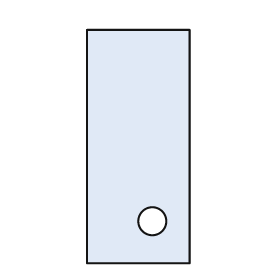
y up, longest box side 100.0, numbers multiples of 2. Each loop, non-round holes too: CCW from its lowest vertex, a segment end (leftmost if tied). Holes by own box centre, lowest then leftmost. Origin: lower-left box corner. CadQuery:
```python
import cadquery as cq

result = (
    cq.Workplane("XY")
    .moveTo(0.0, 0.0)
    .lineTo(44.0, 0.0)
    .lineTo(44.0, 100.0)
    .lineTo(0.0, 100.0)
    .close()
    .moveTo(28.0, 18.0)
    .circle(6.0)
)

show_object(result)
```